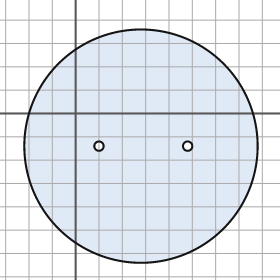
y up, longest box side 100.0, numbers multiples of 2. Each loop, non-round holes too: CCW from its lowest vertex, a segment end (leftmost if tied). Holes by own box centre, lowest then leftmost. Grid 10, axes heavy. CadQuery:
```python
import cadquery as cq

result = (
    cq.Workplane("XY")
    .moveTo(28.0, -14.0)
    .circle(50.0)
    .moveTo(10.0, -14.0)
    .circle(2.0)
    .moveTo(48.0, -14.0)
    .circle(2.0)
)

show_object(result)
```